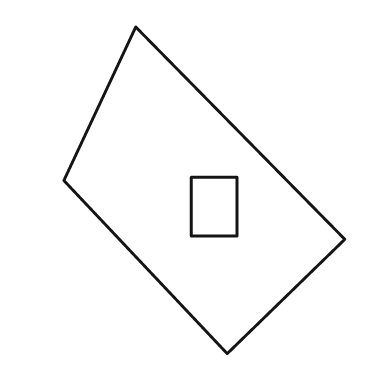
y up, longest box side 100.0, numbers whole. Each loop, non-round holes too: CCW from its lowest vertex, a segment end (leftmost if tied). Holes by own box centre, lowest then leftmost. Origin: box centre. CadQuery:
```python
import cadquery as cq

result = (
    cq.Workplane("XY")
    .moveTo(7.0, -50.0)
    .lineTo(43.0, -15.0)
    .lineTo(-21.0, 50.0)
    .lineTo(-43.0, 3.0)
    .close()
    .moveTo(-4.0, -14.0)
    .lineTo(10.0, -14.0)
    .lineTo(10.0, 4.0)
    .lineTo(-4.0, 4.0)
    .close()
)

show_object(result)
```